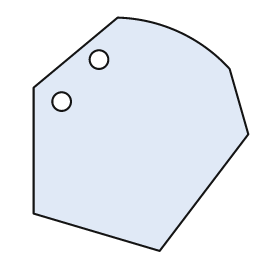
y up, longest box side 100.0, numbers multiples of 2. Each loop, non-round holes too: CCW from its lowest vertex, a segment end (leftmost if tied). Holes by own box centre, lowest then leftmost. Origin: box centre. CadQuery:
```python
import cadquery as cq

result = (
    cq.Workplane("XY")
    .moveTo(8.0, -50.0)
    .lineTo(46.0, 0.0)
    .lineTo(38.0, 28.0)
    .threePointArc((16.0, 44.0), (-10.0, 50.0))
    .lineTo(-46.0, 20.0)
    .lineTo(-46.0, -34.0)
    .close()
    .moveTo(-34.0, 14.0)
    .circle(4.0)
    .moveTo(-18.0, 32.0)
    .circle(4.0)
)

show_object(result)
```